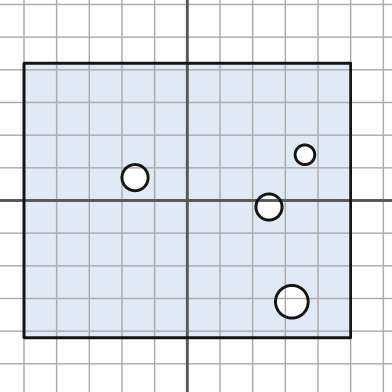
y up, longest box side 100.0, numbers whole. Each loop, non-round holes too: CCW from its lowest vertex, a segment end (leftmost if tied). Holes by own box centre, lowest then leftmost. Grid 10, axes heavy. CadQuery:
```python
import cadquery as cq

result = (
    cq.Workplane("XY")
    .moveTo(-50.0, -42.0)
    .lineTo(50.0, -42.0)
    .lineTo(50.0, 42.0)
    .lineTo(-50.0, 42.0)
    .close()
    .moveTo(32.0, -31.0)
    .circle(5.0)
    .moveTo(25.0, -2.0)
    .circle(4.0)
    .moveTo(-16.0, 7.0)
    .circle(4.0)
    .moveTo(36.0, 14.0)
    .circle(3.0)
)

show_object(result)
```